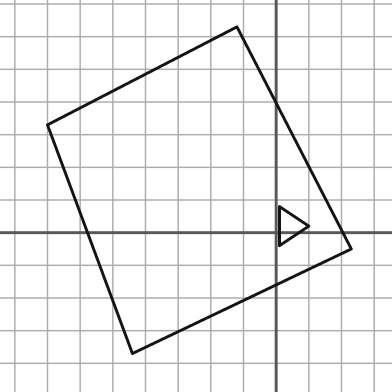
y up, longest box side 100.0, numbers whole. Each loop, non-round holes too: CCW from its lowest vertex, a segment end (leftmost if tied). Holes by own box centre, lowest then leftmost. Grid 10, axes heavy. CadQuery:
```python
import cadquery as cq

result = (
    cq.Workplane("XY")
    .moveTo(-44.0, -37.0)
    .lineTo(23.0, -5.0)
    .lineTo(-12.0, 63.0)
    .lineTo(-70.0, 33.0)
    .close()
    .moveTo(1.0, -4.0)
    .lineTo(10.0, 2.0)
    .lineTo(1.0, 8.0)
    .close()
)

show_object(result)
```